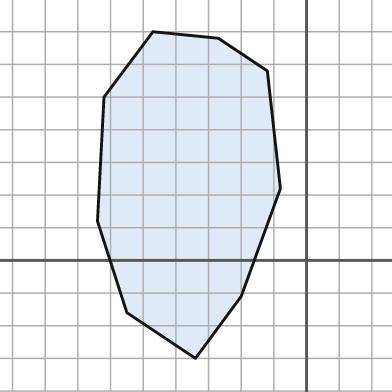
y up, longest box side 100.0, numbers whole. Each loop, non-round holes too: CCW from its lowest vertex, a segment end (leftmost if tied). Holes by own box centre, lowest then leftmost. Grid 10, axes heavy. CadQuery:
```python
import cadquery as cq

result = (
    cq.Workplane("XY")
    .moveTo(-34.0, -30.0)
    .lineTo(-20.0, -11.0)
    .lineTo(-8.0, 22.0)
    .lineTo(-12.0, 58.0)
    .lineTo(-27.0, 68.0)
    .lineTo(-47.0, 70.0)
    .lineTo(-62.0, 50.0)
    .lineTo(-64.0, 12.0)
    .lineTo(-55.0, -16.0)
    .close()
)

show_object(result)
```